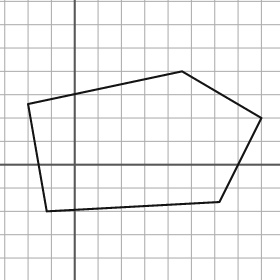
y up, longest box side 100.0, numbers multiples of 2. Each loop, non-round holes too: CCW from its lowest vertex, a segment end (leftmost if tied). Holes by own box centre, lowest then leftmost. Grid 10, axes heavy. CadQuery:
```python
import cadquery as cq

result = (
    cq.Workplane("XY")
    .moveTo(-12.0, -20.0)
    .lineTo(62.0, -16.0)
    .lineTo(80.0, 20.0)
    .lineTo(46.0, 40.0)
    .lineTo(-20.0, 26.0)
    .close()
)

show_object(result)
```